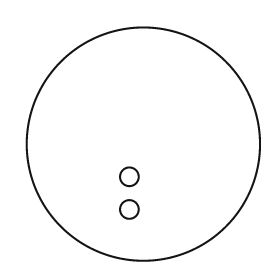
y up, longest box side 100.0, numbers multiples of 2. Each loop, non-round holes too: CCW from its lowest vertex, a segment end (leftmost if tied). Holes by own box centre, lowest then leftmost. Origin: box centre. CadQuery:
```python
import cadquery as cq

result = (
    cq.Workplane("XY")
    .moveTo(0.0, 0.0)
    .circle(50.0)
    .moveTo(-6.0, -28.0)
    .circle(4.0)
    .moveTo(-6.0, -14.0)
    .circle(4.0)
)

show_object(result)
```